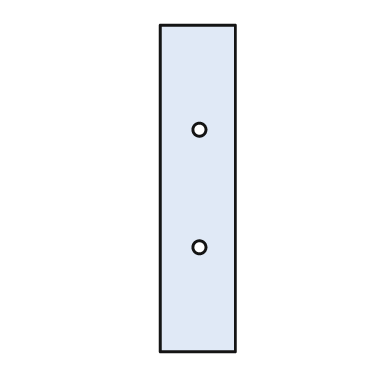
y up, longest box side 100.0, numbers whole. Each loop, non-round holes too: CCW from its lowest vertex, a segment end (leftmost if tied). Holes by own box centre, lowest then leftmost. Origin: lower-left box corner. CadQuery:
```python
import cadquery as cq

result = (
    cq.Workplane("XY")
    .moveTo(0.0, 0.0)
    .lineTo(23.0, 0.0)
    .lineTo(23.0, 100.0)
    .lineTo(0.0, 100.0)
    .close()
    .moveTo(12.0, 32.0)
    .circle(2.0)
    .moveTo(12.0, 68.0)
    .circle(2.0)
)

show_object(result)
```